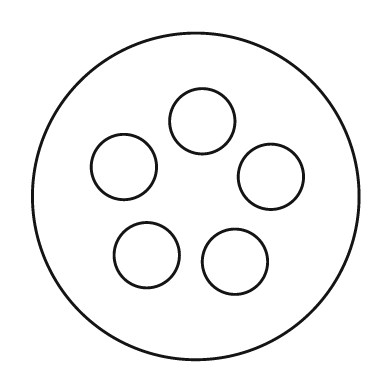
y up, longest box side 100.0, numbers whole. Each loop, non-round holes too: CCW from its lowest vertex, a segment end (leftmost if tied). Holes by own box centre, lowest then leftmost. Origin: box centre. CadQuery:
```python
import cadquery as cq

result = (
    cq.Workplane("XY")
    .moveTo(0.0, 0.0)
    .circle(50.0)
    .moveTo(12.0, -20.0)
    .circle(10.0)
    .moveTo(-15.0, -18.0)
    .circle(10.0)
    .moveTo(23.0, 6.0)
    .circle(10.0)
    .moveTo(-22.0, 9.0)
    .circle(10.0)
    .moveTo(2.0, 23.0)
    .circle(10.0)
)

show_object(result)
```